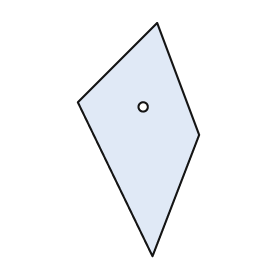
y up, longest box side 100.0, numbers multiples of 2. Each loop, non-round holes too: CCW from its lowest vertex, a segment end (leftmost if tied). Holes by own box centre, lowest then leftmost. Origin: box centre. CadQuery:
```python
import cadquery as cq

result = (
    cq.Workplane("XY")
    .moveTo(6.0, -50.0)
    .lineTo(26.0, 2.0)
    .lineTo(8.0, 50.0)
    .lineTo(-26.0, 16.0)
    .close()
    .moveTo(2.0, 14.0)
    .circle(2.0)
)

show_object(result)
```